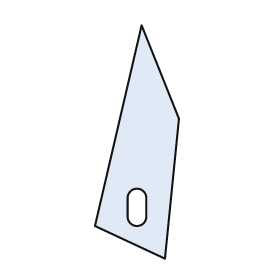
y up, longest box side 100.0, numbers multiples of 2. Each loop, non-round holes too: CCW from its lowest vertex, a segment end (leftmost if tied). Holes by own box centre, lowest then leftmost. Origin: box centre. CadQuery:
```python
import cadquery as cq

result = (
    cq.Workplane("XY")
    .moveTo(12.0, -50.0)
    .lineTo(18.0, 10.0)
    .lineTo(2.0, 50.0)
    .lineTo(-18.0, -36.0)
    .close()
    .moveTo(-4.0, -32.0)
    .threePointArc((0.0, -36.0), (4.0, -32.0))
    .lineTo(4.0, -24.0)
    .threePointArc((0.0, -20.0), (-4.0, -24.0))
    .close()
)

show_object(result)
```